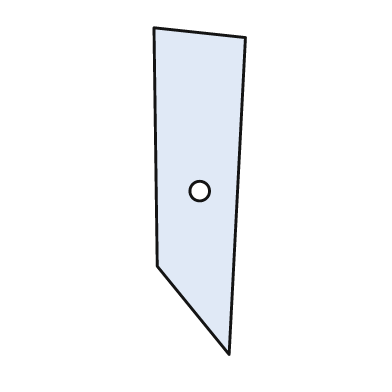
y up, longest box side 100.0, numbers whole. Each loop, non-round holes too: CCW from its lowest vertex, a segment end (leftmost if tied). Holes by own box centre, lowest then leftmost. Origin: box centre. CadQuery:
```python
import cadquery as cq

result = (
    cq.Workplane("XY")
    .moveTo(9.0, -50.0)
    .lineTo(14.0, 47.0)
    .lineTo(-14.0, 50.0)
    .lineTo(-13.0, -23.0)
    .close()
    .moveTo(0.0, 0.0)
    .circle(3.0)
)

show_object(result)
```